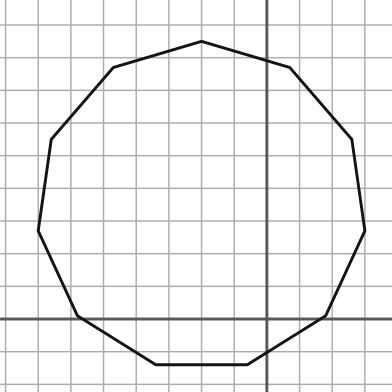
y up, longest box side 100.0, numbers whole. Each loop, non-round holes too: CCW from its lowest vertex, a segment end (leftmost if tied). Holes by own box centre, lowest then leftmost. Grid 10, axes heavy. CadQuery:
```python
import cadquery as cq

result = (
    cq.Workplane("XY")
    .moveTo(-34.0, -14.0)
    .lineTo(-6.0, -14.0)
    .lineTo(18.0, 1.0)
    .lineTo(30.0, 27.0)
    .lineTo(26.0, 55.0)
    .lineTo(7.0, 77.0)
    .lineTo(-20.0, 85.0)
    .lineTo(-47.0, 77.0)
    .lineTo(-66.0, 55.0)
    .lineTo(-70.0, 27.0)
    .lineTo(-58.0, 1.0)
    .close()
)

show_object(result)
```